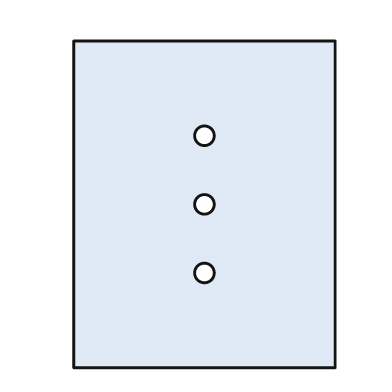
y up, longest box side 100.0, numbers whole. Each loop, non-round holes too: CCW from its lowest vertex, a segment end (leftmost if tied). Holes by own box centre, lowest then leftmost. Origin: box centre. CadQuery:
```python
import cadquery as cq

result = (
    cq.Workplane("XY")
    .moveTo(-40.0, -50.0)
    .lineTo(40.0, -50.0)
    .lineTo(40.0, 50.0)
    .lineTo(-40.0, 50.0)
    .close()
    .moveTo(0.0, -21.0)
    .circle(3.0)
    .moveTo(0.0, 0.0)
    .circle(3.0)
    .moveTo(0.0, 21.0)
    .circle(3.0)
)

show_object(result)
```